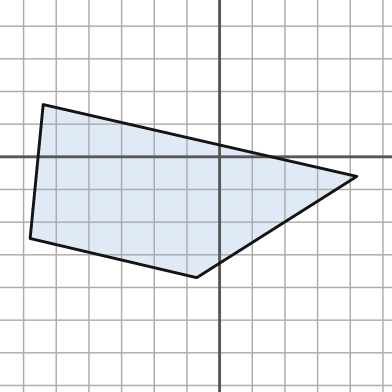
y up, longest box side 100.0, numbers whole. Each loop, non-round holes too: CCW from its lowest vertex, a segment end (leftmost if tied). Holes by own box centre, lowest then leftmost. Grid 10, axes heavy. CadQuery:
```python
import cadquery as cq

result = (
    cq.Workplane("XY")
    .moveTo(-7.0, -37.0)
    .lineTo(42.0, -6.0)
    .lineTo(-54.0, 16.0)
    .lineTo(-58.0, -25.0)
    .close()
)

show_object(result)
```